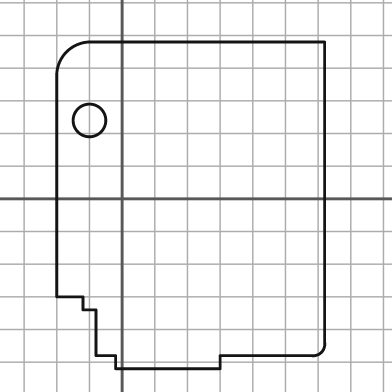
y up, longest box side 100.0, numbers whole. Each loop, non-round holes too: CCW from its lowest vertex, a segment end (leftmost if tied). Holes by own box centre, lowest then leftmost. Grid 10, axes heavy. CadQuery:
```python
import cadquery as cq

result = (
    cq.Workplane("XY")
    .moveTo(-2.0, -52.0)
    .lineTo(30.0, -52.0)
    .lineTo(30.0, -48.0)
    .lineTo(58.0, -48.0)
    .threePointArc((61.0, -47.0), (62.0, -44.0))
    .lineTo(62.0, 48.0)
    .lineTo(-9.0, 48.0)
    .threePointArc((-17.0, 45.0), (-20.0, 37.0))
    .lineTo(-20.0, -30.0)
    .lineTo(-12.0, -30.0)
    .lineTo(-12.0, -34.0)
    .lineTo(-8.0, -34.0)
    .lineTo(-8.0, -48.0)
    .lineTo(-2.0, -48.0)
    .close()
    .moveTo(-10.0, 24.0)
    .circle(5.0)
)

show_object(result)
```